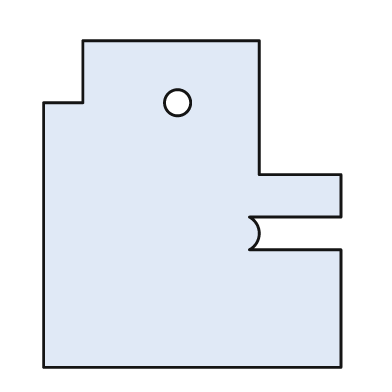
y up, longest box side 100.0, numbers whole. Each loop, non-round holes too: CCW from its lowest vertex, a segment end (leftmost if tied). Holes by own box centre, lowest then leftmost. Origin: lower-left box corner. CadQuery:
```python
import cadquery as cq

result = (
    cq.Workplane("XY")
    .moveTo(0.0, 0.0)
    .lineTo(91.0, 0.0)
    .lineTo(91.0, 36.0)
    .lineTo(63.0, 36.0)
    .threePointArc((66.0, 41.0), (63.0, 46.0))
    .lineTo(91.0, 46.0)
    .lineTo(91.0, 59.0)
    .lineTo(66.0, 59.0)
    .lineTo(66.0, 100.0)
    .lineTo(12.0, 100.0)
    .lineTo(12.0, 81.0)
    .lineTo(0.0, 81.0)
    .close()
    .moveTo(41.0, 81.0)
    .circle(4.0)
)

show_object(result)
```